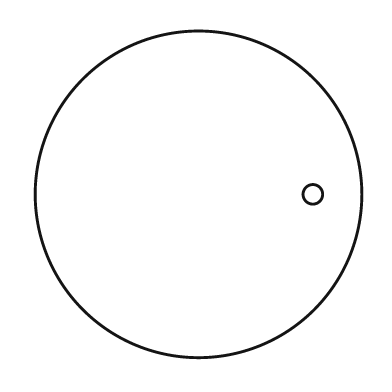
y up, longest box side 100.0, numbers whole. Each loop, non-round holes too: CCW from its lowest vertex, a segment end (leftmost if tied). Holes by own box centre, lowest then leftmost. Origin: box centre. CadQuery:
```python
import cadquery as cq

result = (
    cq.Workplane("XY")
    .moveTo(0.0, 0.0)
    .circle(50.0)
    .moveTo(35.0, 0.0)
    .circle(3.0)
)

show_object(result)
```